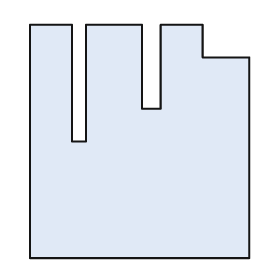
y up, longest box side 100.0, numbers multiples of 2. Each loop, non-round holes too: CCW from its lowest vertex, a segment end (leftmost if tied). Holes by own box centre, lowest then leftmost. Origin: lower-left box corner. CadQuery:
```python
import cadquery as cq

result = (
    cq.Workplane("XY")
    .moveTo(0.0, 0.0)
    .lineTo(94.0, 0.0)
    .lineTo(94.0, 86.0)
    .lineTo(74.0, 86.0)
    .lineTo(74.0, 100.0)
    .lineTo(56.0, 100.0)
    .lineTo(56.0, 64.0)
    .lineTo(48.0, 64.0)
    .lineTo(48.0, 100.0)
    .lineTo(24.0, 100.0)
    .lineTo(24.0, 50.0)
    .lineTo(18.0, 50.0)
    .lineTo(18.0, 100.0)
    .lineTo(0.0, 100.0)
    .close()
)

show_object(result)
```